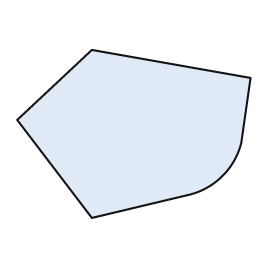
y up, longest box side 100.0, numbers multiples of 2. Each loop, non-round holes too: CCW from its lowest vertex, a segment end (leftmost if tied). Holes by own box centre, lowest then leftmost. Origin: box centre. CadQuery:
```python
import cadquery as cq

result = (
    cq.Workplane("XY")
    .moveTo(-18.0, -36.0)
    .lineTo(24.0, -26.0)
    .threePointArc((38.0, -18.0), (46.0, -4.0))
    .lineTo(50.0, 24.0)
    .lineTo(-18.0, 36.0)
    .lineTo(-50.0, 6.0)
    .close()
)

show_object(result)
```